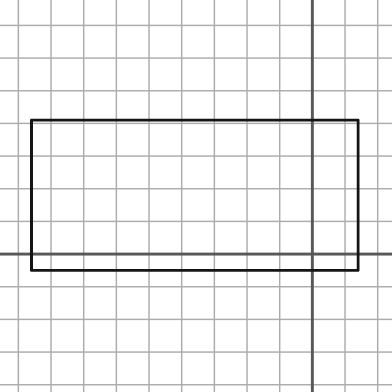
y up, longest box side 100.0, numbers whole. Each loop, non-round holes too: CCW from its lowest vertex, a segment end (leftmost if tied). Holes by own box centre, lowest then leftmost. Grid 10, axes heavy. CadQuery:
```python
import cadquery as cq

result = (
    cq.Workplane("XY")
    .moveTo(-86.0, -5.0)
    .lineTo(14.0, -5.0)
    .lineTo(14.0, 41.0)
    .lineTo(-86.0, 41.0)
    .close()
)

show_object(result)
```